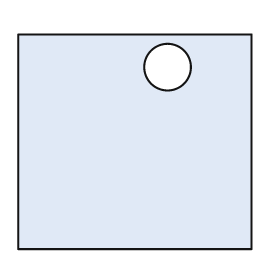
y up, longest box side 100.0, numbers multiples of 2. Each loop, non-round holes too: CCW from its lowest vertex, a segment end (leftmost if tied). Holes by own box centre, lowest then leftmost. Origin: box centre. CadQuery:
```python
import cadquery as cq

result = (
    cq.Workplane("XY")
    .moveTo(-50.0, -46.0)
    .lineTo(50.0, -46.0)
    .lineTo(50.0, 46.0)
    .lineTo(-50.0, 46.0)
    .close()
    .moveTo(14.0, 32.0)
    .circle(10.0)
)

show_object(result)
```